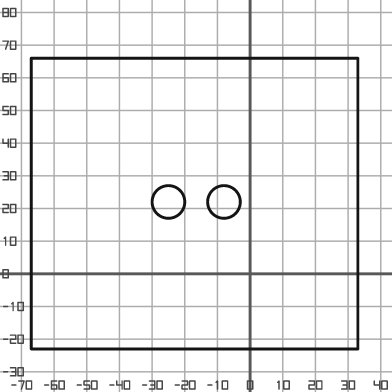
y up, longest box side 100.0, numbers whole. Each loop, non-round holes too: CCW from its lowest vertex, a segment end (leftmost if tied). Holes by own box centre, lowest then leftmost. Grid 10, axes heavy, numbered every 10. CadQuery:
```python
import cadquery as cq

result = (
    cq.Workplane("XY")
    .moveTo(-67.0, -23.0)
    .lineTo(33.0, -23.0)
    .lineTo(33.0, 66.0)
    .lineTo(-67.0, 66.0)
    .close()
    .moveTo(-25.0, 22.0)
    .circle(5.0)
    .moveTo(-8.0, 22.0)
    .circle(5.0)
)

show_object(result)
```